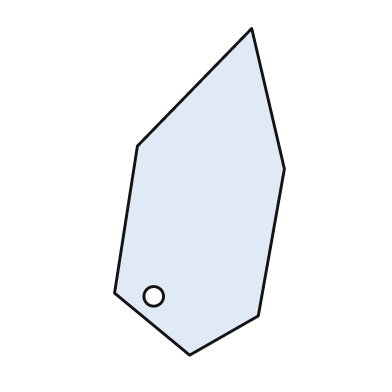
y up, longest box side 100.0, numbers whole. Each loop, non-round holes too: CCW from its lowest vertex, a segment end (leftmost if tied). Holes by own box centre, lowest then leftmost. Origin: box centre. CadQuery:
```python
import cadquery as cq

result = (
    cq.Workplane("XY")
    .moveTo(-3.0, -50.0)
    .lineTo(18.0, -38.0)
    .lineTo(26.0, 7.0)
    .lineTo(16.0, 50.0)
    .lineTo(-19.0, 14.0)
    .lineTo(-26.0, -31.0)
    .close()
    .moveTo(-14.0, -32.0)
    .circle(3.0)
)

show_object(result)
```